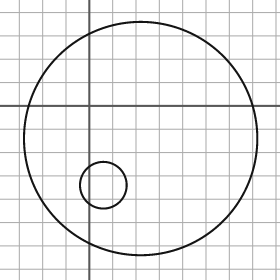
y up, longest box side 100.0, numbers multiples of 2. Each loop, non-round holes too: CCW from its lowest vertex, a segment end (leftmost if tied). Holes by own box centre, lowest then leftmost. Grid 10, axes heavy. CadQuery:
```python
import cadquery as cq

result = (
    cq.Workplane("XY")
    .moveTo(22.0, -14.0)
    .circle(50.0)
    .moveTo(6.0, -34.0)
    .circle(10.0)
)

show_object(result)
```